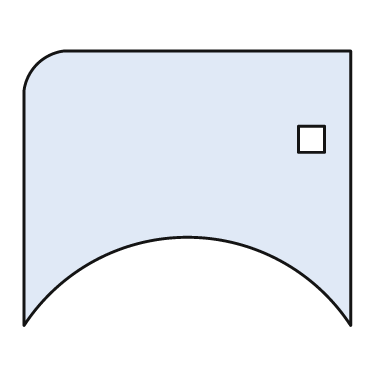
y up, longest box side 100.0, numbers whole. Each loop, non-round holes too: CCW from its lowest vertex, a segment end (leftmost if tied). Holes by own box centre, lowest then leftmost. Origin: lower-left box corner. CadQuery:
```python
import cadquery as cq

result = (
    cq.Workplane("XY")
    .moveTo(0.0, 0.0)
    .threePointArc((50.0, 27.0), (100.0, 0.0))
    .lineTo(100.0, 84.0)
    .lineTo(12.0, 84.0)
    .threePointArc((4.0, 80.0), (0.0, 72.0))
    .close()
    .moveTo(84.0, 53.0)
    .lineTo(92.0, 53.0)
    .lineTo(92.0, 61.0)
    .lineTo(84.0, 61.0)
    .close()
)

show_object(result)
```